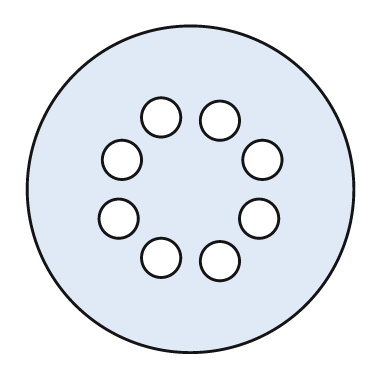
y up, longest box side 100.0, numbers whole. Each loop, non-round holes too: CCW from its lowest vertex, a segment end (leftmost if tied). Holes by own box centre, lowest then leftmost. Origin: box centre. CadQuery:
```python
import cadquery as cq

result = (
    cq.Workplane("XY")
    .moveTo(0.0, 0.0)
    .circle(50.0)
    .moveTo(9.0, -22.0)
    .circle(6.0)
    .moveTo(-9.0, -21.0)
    .circle(6.0)
    .moveTo(-22.0, -9.0)
    .circle(6.0)
    .moveTo(21.0, -9.0)
    .circle(6.0)
    .moveTo(-21.0, 9.0)
    .circle(6.0)
    .moveTo(22.0, 9.0)
    .circle(6.0)
    .moveTo(9.0, 21.0)
    .circle(6.0)
    .moveTo(-9.0, 22.0)
    .circle(6.0)
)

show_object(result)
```